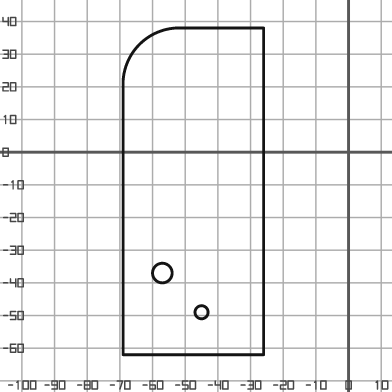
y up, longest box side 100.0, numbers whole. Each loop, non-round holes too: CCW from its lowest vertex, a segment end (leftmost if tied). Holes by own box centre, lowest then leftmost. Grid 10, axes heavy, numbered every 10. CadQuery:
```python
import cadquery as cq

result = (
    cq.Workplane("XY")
    .moveTo(-69.0, -62.0)
    .lineTo(-26.0, -62.0)
    .lineTo(-26.0, 38.0)
    .lineTo(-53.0, 38.0)
    .threePointArc((-64.0, 33.0), (-69.0, 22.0))
    .close()
    .moveTo(-45.0, -49.0)
    .circle(2.0)
    .moveTo(-57.0, -37.0)
    .circle(3.0)
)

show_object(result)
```